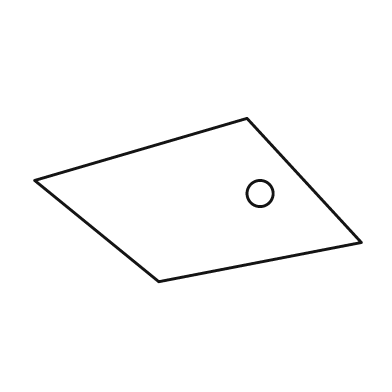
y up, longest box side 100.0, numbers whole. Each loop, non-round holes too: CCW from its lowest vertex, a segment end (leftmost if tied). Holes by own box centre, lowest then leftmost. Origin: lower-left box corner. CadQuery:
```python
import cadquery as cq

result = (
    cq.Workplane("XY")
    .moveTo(38.0, 0.0)
    .lineTo(100.0, 12.0)
    .lineTo(65.0, 50.0)
    .lineTo(0.0, 31.0)
    .close()
    .moveTo(69.0, 27.0)
    .circle(4.0)
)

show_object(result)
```